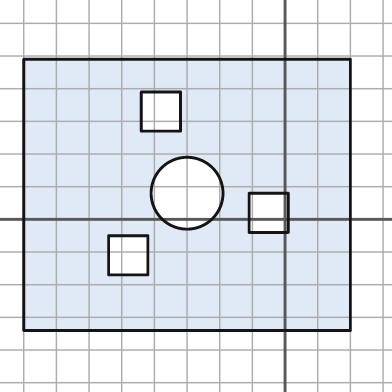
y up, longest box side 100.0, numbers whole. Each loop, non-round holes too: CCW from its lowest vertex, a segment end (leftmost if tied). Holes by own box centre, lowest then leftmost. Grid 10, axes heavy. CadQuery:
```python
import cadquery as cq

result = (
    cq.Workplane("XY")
    .moveTo(-80.0, -34.0)
    .lineTo(20.0, -34.0)
    .lineTo(20.0, 49.0)
    .lineTo(-80.0, 49.0)
    .close()
    .moveTo(-54.0, -17.0)
    .lineTo(-42.0, -17.0)
    .lineTo(-42.0, -5.0)
    .lineTo(-54.0, -5.0)
    .close()
    .moveTo(-11.0, -4.0)
    .lineTo(1.0, -4.0)
    .lineTo(1.0, 8.0)
    .lineTo(-11.0, 8.0)
    .close()
    .moveTo(-30.0, 8.0)
    .circle(11.0)
    .moveTo(-44.0, 27.0)
    .lineTo(-32.0, 27.0)
    .lineTo(-32.0, 39.0)
    .lineTo(-44.0, 39.0)
    .close()
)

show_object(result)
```